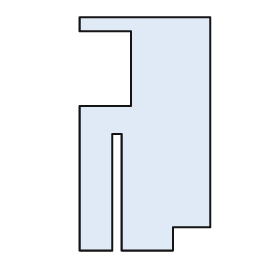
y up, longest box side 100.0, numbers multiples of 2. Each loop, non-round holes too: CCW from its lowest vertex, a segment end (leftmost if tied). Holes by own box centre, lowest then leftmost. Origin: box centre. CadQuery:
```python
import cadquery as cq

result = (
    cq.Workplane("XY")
    .moveTo(-28.0, -50.0)
    .lineTo(-14.0, -50.0)
    .lineTo(-14.0, 0.0)
    .lineTo(-10.0, 0.0)
    .lineTo(-10.0, -50.0)
    .lineTo(12.0, -50.0)
    .lineTo(12.0, -40.0)
    .lineTo(28.0, -40.0)
    .lineTo(28.0, 50.0)
    .lineTo(-28.0, 50.0)
    .lineTo(-28.0, 44.0)
    .lineTo(-6.0, 44.0)
    .lineTo(-6.0, 12.0)
    .lineTo(-28.0, 12.0)
    .close()
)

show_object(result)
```